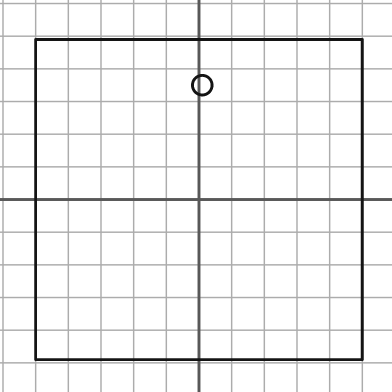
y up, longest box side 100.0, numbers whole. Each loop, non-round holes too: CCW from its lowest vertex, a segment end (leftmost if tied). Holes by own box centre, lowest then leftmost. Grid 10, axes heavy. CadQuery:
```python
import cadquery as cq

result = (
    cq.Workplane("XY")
    .moveTo(-50.0, -49.0)
    .lineTo(50.0, -49.0)
    .lineTo(50.0, 49.0)
    .lineTo(-50.0, 49.0)
    .close()
    .moveTo(1.0, 35.0)
    .circle(3.0)
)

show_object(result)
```